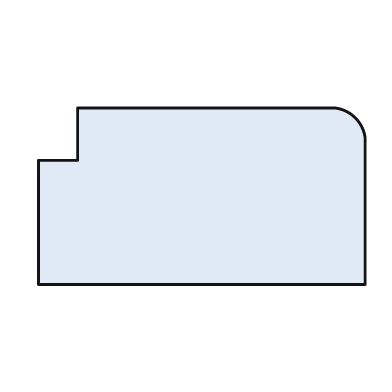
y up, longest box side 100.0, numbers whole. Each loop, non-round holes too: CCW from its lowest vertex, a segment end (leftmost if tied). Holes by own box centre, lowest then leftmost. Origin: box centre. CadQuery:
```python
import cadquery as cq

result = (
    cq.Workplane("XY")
    .moveTo(-50.0, -27.0)
    .lineTo(50.0, -27.0)
    .lineTo(50.0, 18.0)
    .threePointArc((47.0, 24.0), (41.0, 27.0))
    .lineTo(-38.0, 27.0)
    .lineTo(-38.0, 11.0)
    .lineTo(-50.0, 11.0)
    .close()
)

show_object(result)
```